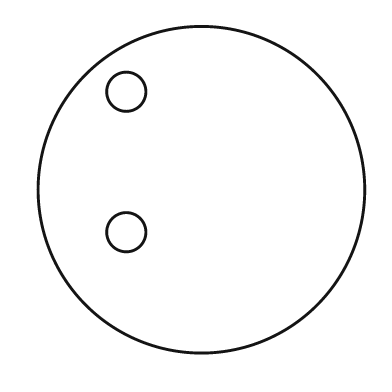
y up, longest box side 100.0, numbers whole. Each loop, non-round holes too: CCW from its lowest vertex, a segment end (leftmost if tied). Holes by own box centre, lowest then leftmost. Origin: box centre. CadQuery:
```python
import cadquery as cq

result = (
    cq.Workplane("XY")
    .moveTo(0.0, 0.0)
    .circle(50.0)
    .moveTo(-23.0, -13.0)
    .circle(6.0)
    .moveTo(-23.0, 30.0)
    .circle(6.0)
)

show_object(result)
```